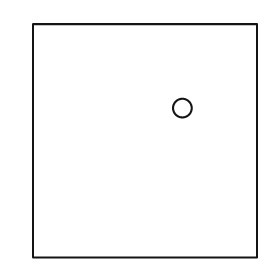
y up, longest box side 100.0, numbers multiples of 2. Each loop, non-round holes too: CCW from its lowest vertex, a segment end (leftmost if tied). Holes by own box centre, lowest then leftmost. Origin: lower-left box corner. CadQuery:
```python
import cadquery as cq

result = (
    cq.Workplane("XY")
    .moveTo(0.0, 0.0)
    .lineTo(96.0, 0.0)
    .lineTo(96.0, 100.0)
    .lineTo(0.0, 100.0)
    .close()
    .moveTo(64.0, 64.0)
    .circle(4.0)
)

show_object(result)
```